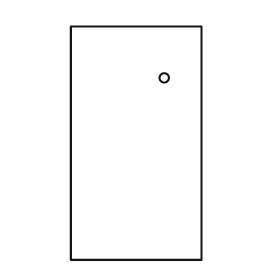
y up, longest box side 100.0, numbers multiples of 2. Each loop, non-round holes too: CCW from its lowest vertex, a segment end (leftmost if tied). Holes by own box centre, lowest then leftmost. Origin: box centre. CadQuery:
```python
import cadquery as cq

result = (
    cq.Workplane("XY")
    .moveTo(-28.0, -50.0)
    .lineTo(28.0, -50.0)
    .lineTo(28.0, 50.0)
    .lineTo(-28.0, 50.0)
    .close()
    .moveTo(12.0, 28.0)
    .circle(2.0)
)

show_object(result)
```